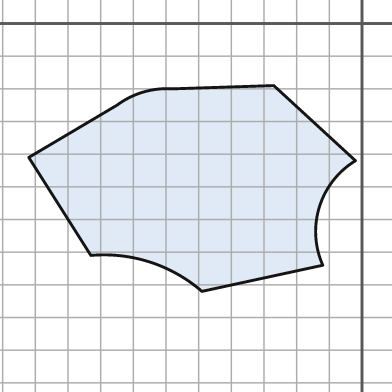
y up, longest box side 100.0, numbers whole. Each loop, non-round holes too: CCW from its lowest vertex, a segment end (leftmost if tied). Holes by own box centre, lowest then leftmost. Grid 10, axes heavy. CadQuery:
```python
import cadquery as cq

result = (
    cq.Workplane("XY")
    .moveTo(-49.0, -82.0)
    .lineTo(-12.0, -74.0)
    .threePointArc((-13.0, -56.0), (-2.0, -42.0))
    .lineTo(-27.0, -19.0)
    .lineTo(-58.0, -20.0)
    .threePointArc((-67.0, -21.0), (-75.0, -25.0))
    .lineTo(-102.0, -41.0)
    .lineTo(-83.0, -71.0)
    .threePointArc((-65.0, -73.0), (-49.0, -82.0))
    .close()
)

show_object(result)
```